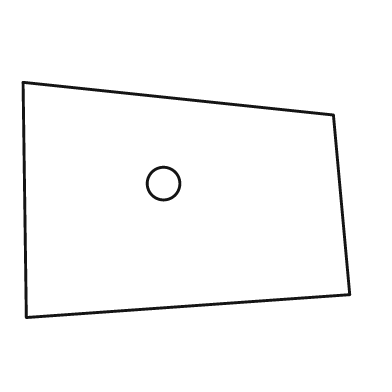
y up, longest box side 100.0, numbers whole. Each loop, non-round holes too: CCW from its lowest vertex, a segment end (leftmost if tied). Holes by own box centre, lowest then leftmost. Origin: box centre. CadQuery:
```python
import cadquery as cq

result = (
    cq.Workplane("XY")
    .moveTo(-49.0, -36.0)
    .lineTo(50.0, -29.0)
    .lineTo(45.0, 26.0)
    .lineTo(-50.0, 36.0)
    .close()
    .moveTo(-7.0, 5.0)
    .circle(5.0)
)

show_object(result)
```